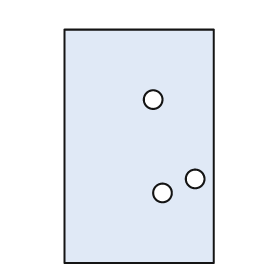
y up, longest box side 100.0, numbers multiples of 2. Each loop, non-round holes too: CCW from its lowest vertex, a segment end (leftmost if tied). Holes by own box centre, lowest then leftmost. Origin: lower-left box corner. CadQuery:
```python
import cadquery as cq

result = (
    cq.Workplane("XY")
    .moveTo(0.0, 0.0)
    .lineTo(64.0, 0.0)
    .lineTo(64.0, 100.0)
    .lineTo(0.0, 100.0)
    .close()
    .moveTo(42.0, 30.0)
    .circle(4.0)
    .moveTo(56.0, 36.0)
    .circle(4.0)
    .moveTo(38.0, 70.0)
    .circle(4.0)
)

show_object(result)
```